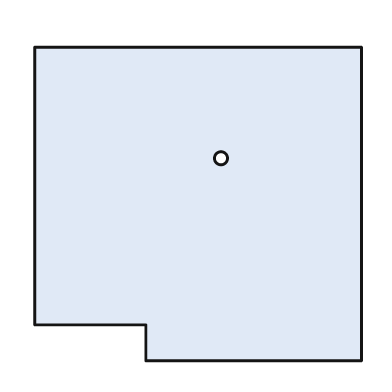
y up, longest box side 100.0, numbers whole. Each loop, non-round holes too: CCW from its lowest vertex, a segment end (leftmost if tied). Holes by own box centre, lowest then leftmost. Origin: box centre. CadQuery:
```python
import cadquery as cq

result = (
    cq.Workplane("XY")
    .moveTo(-16.0, -48.0)
    .lineTo(50.0, -48.0)
    .lineTo(50.0, 48.0)
    .lineTo(-50.0, 48.0)
    .lineTo(-50.0, -37.0)
    .lineTo(-16.0, -37.0)
    .close()
    .moveTo(7.0, 14.0)
    .circle(2.0)
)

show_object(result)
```